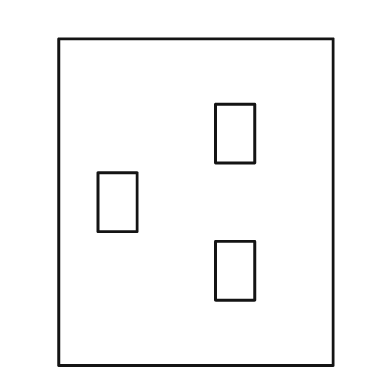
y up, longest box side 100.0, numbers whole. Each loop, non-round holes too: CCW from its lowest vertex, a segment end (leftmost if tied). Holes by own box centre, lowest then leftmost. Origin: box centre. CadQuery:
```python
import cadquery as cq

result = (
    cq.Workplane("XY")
    .moveTo(-42.0, -50.0)
    .lineTo(42.0, -50.0)
    .lineTo(42.0, 50.0)
    .lineTo(-42.0, 50.0)
    .close()
    .moveTo(6.0, -30.0)
    .lineTo(18.0, -30.0)
    .lineTo(18.0, -12.0)
    .lineTo(6.0, -12.0)
    .close()
    .moveTo(-30.0, -9.0)
    .lineTo(-18.0, -9.0)
    .lineTo(-18.0, 9.0)
    .lineTo(-30.0, 9.0)
    .close()
    .moveTo(6.0, 12.0)
    .lineTo(18.0, 12.0)
    .lineTo(18.0, 30.0)
    .lineTo(6.0, 30.0)
    .close()
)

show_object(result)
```